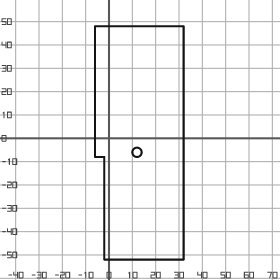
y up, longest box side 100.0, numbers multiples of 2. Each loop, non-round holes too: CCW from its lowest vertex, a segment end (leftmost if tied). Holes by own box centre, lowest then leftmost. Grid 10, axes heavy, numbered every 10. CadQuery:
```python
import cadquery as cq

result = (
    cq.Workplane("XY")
    .moveTo(-2.0, -52.0)
    .lineTo(32.0, -52.0)
    .lineTo(32.0, 48.0)
    .lineTo(-6.0, 48.0)
    .lineTo(-6.0, -8.0)
    .lineTo(-2.0, -8.0)
    .close()
    .moveTo(12.0, -6.0)
    .circle(2.0)
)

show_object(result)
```